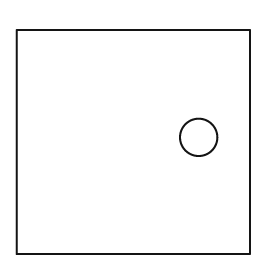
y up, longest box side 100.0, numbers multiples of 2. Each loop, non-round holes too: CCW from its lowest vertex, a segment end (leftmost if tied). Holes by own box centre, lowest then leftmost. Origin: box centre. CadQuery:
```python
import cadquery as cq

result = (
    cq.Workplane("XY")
    .moveTo(-50.0, -48.0)
    .lineTo(50.0, -48.0)
    .lineTo(50.0, 48.0)
    .lineTo(-50.0, 48.0)
    .close()
    .moveTo(28.0, 2.0)
    .circle(8.0)
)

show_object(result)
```